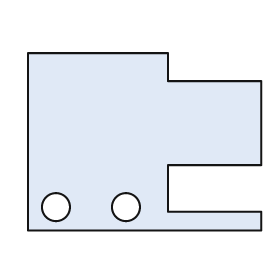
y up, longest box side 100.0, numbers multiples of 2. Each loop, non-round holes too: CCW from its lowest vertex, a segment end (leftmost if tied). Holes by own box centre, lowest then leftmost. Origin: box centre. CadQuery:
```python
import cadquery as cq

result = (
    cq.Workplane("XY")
    .moveTo(-50.0, -38.0)
    .lineTo(50.0, -38.0)
    .lineTo(50.0, -30.0)
    .lineTo(10.0, -30.0)
    .lineTo(10.0, -10.0)
    .lineTo(50.0, -10.0)
    .lineTo(50.0, 26.0)
    .lineTo(10.0, 26.0)
    .lineTo(10.0, 38.0)
    .lineTo(-50.0, 38.0)
    .close()
    .moveTo(-38.0, -28.0)
    .circle(6.0)
    .moveTo(-8.0, -28.0)
    .circle(6.0)
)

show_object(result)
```